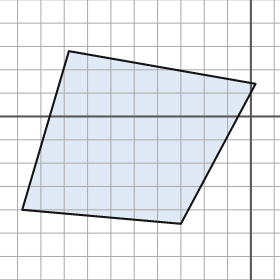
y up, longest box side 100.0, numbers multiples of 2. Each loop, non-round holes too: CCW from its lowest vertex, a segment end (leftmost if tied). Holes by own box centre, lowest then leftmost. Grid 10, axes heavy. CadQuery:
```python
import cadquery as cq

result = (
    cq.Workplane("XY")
    .moveTo(-30.0, -46.0)
    .lineTo(2.0, 14.0)
    .lineTo(-78.0, 28.0)
    .lineTo(-98.0, -40.0)
    .close()
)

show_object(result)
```